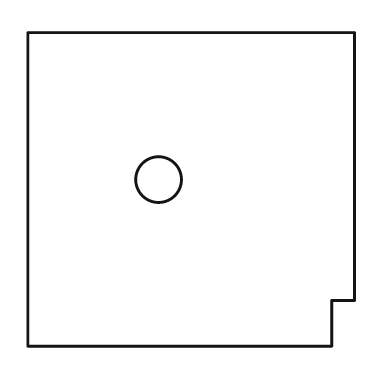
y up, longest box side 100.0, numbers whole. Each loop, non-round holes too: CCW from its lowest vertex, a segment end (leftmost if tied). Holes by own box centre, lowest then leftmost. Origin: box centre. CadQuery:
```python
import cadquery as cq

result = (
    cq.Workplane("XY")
    .moveTo(-50.0, -48.0)
    .lineTo(43.0, -48.0)
    .lineTo(43.0, -34.0)
    .lineTo(50.0, -34.0)
    .lineTo(50.0, 48.0)
    .lineTo(-50.0, 48.0)
    .close()
    .moveTo(-10.0, 3.0)
    .circle(7.0)
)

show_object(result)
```